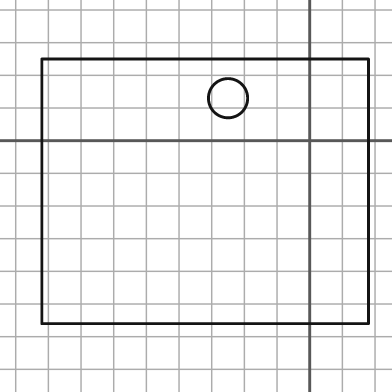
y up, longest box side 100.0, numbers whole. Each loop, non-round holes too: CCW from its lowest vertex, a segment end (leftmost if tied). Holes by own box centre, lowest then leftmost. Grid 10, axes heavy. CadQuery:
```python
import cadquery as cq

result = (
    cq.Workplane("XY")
    .moveTo(-82.0, -56.0)
    .lineTo(18.0, -56.0)
    .lineTo(18.0, 25.0)
    .lineTo(-82.0, 25.0)
    .close()
    .moveTo(-25.0, 13.0)
    .circle(6.0)
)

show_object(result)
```